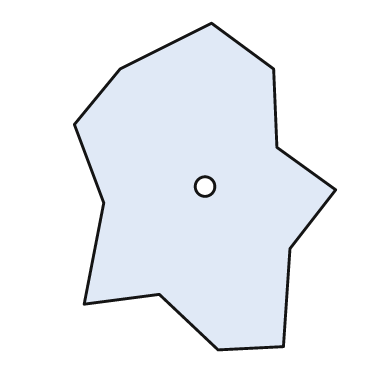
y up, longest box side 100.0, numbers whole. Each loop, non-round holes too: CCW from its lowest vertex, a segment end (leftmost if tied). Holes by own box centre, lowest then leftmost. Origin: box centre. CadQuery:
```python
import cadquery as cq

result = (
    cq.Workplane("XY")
    .moveTo(4.0, -50.0)
    .lineTo(24.0, -49.0)
    .lineTo(26.0, -19.0)
    .lineTo(40.0, -1.0)
    .lineTo(22.0, 12.0)
    .lineTo(21.0, 36.0)
    .lineTo(2.0, 50.0)
    .lineTo(-26.0, 36.0)
    .lineTo(-40.0, 19.0)
    .lineTo(-31.0, -5.0)
    .lineTo(-37.0, -36.0)
    .lineTo(-14.0, -33.0)
    .close()
    .moveTo(0.0, 0.0)
    .circle(3.0)
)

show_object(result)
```